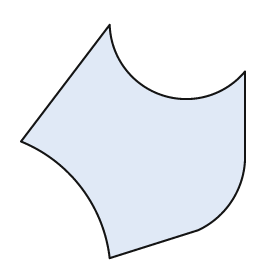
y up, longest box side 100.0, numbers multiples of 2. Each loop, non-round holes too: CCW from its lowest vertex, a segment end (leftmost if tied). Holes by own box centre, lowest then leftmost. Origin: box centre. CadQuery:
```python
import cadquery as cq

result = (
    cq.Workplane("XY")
    .moveTo(-10.0, -50.0)
    .lineTo(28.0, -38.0)
    .threePointArc((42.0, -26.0), (48.0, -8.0))
    .lineTo(48.0, 30.0)
    .threePointArc((12.0, 20.0), (-10.0, 50.0))
    .lineTo(-48.0, 0.0)
    .threePointArc((-22.0, -20.0), (-10.0, -50.0))
    .close()
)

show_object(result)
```